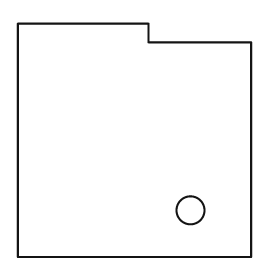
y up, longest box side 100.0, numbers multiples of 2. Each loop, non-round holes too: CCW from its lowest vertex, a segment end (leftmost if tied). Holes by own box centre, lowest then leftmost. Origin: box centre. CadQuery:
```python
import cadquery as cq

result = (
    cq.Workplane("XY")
    .moveTo(-50.0, -50.0)
    .lineTo(50.0, -50.0)
    .lineTo(50.0, 42.0)
    .lineTo(6.0, 42.0)
    .lineTo(6.0, 50.0)
    .lineTo(-50.0, 50.0)
    .close()
    .moveTo(24.0, -30.0)
    .circle(6.0)
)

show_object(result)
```